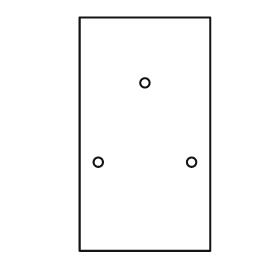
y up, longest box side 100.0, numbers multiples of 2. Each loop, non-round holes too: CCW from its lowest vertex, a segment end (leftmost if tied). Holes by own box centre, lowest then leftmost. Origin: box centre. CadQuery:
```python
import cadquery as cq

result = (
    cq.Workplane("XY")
    .moveTo(-28.0, -50.0)
    .lineTo(28.0, -50.0)
    .lineTo(28.0, 50.0)
    .lineTo(-28.0, 50.0)
    .close()
    .moveTo(-20.0, -12.0)
    .circle(2.0)
    .moveTo(20.0, -12.0)
    .circle(2.0)
    .moveTo(0.0, 22.0)
    .circle(2.0)
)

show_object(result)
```